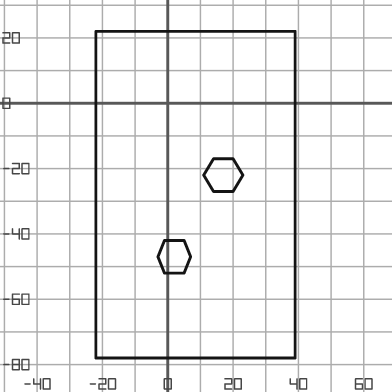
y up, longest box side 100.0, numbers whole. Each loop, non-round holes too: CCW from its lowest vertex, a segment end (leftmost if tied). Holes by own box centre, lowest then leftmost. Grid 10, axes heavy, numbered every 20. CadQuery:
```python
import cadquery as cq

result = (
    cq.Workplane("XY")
    .moveTo(-22.0, -78.0)
    .lineTo(39.0, -78.0)
    .lineTo(39.0, 22.0)
    .lineTo(-22.0, 22.0)
    .close()
    .moveTo(-1.0, -52.0)
    .lineTo(5.0, -52.0)
    .lineTo(7.0, -47.0)
    .lineTo(5.0, -42.0)
    .lineTo(-1.0, -42.0)
    .lineTo(-3.0, -47.0)
    .close()
    .moveTo(14.0, -27.0)
    .lineTo(20.0, -27.0)
    .lineTo(23.0, -22.0)
    .lineTo(20.0, -17.0)
    .lineTo(14.0, -17.0)
    .lineTo(11.0, -22.0)
    .close()
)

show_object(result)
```